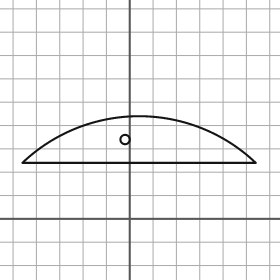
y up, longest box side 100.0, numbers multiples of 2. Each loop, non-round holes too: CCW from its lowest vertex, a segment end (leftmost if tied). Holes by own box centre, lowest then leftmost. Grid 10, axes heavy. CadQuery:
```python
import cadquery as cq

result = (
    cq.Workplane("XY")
    .moveTo(-46.0, 24.0)
    .lineTo(54.0, 24.0)
    .threePointArc((4.0, 44.0), (-46.0, 24.0))
    .close()
    .moveTo(-2.0, 34.0)
    .circle(2.0)
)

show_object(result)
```